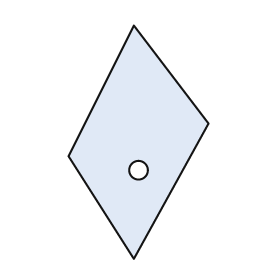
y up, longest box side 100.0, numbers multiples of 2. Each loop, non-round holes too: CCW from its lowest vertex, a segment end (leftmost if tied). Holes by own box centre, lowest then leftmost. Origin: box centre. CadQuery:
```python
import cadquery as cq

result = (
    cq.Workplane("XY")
    .moveTo(-2.0, -50.0)
    .lineTo(30.0, 8.0)
    .lineTo(-2.0, 50.0)
    .lineTo(-30.0, -6.0)
    .close()
    .moveTo(0.0, -12.0)
    .circle(4.0)
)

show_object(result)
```